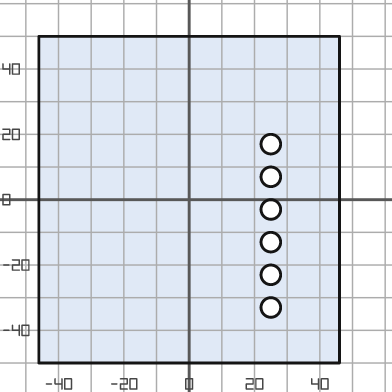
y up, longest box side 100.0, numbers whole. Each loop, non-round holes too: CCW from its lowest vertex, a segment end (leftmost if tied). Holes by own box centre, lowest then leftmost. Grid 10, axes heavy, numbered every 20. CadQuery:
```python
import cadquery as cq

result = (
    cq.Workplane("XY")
    .moveTo(-46.0, -50.0)
    .lineTo(46.0, -50.0)
    .lineTo(46.0, 50.0)
    .lineTo(-46.0, 50.0)
    .close()
    .moveTo(25.0, -33.0)
    .circle(3.0)
    .moveTo(25.0, -23.0)
    .circle(3.0)
    .moveTo(25.0, -13.0)
    .circle(3.0)
    .moveTo(25.0, -3.0)
    .circle(3.0)
    .moveTo(25.0, 7.0)
    .circle(3.0)
    .moveTo(25.0, 17.0)
    .circle(3.0)
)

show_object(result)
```